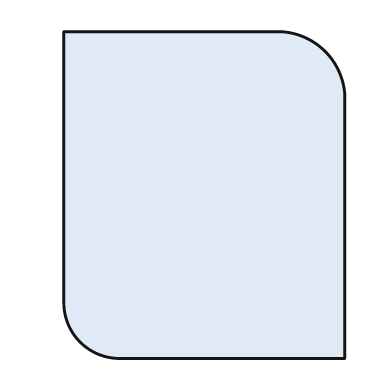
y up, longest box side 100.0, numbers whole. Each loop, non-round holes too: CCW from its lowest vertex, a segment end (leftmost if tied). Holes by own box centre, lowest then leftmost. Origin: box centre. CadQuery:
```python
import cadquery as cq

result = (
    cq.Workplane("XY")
    .moveTo(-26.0, -50.0)
    .lineTo(43.0, -50.0)
    .lineTo(43.0, 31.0)
    .threePointArc((37.0, 44.0), (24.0, 50.0))
    .lineTo(-43.0, 50.0)
    .lineTo(-43.0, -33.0)
    .threePointArc((-38.0, -45.0), (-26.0, -50.0))
    .close()
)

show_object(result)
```